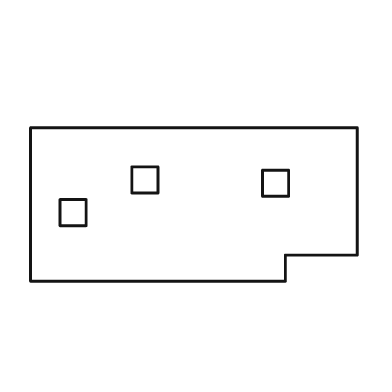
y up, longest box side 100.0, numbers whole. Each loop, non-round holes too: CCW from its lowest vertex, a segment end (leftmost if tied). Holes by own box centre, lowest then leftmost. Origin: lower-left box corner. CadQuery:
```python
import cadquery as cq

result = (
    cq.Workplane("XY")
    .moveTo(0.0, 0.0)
    .lineTo(78.0, 0.0)
    .lineTo(78.0, 8.0)
    .lineTo(100.0, 8.0)
    .lineTo(100.0, 47.0)
    .lineTo(0.0, 47.0)
    .close()
    .moveTo(9.0, 17.0)
    .lineTo(17.0, 17.0)
    .lineTo(17.0, 25.0)
    .lineTo(9.0, 25.0)
    .close()
    .moveTo(71.0, 26.0)
    .lineTo(79.0, 26.0)
    .lineTo(79.0, 34.0)
    .lineTo(71.0, 34.0)
    .close()
    .moveTo(31.0, 27.0)
    .lineTo(39.0, 27.0)
    .lineTo(39.0, 35.0)
    .lineTo(31.0, 35.0)
    .close()
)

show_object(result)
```